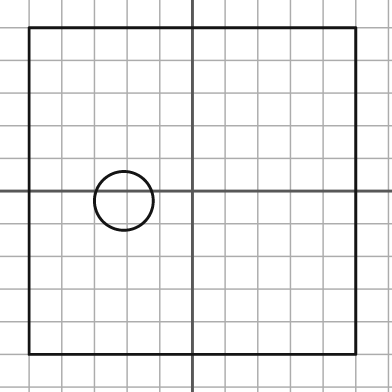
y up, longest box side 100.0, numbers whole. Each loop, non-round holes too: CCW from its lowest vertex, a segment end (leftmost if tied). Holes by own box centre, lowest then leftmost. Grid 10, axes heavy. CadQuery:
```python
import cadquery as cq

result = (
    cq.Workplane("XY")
    .moveTo(-50.0, -50.0)
    .lineTo(50.0, -50.0)
    .lineTo(50.0, 50.0)
    .lineTo(-50.0, 50.0)
    .close()
    .moveTo(-21.0, -3.0)
    .circle(9.0)
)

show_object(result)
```